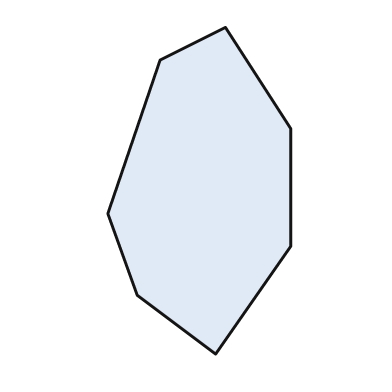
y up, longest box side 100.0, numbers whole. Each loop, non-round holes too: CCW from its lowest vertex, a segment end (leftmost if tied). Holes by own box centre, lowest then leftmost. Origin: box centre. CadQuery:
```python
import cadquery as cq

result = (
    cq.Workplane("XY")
    .moveTo(5.0, -50.0)
    .lineTo(28.0, -17.0)
    .lineTo(28.0, 19.0)
    .lineTo(8.0, 50.0)
    .lineTo(-12.0, 40.0)
    .lineTo(-28.0, -7.0)
    .lineTo(-19.0, -32.0)
    .close()
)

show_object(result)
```